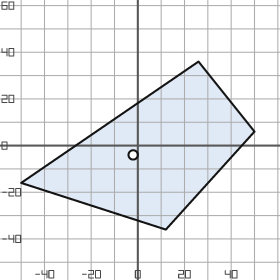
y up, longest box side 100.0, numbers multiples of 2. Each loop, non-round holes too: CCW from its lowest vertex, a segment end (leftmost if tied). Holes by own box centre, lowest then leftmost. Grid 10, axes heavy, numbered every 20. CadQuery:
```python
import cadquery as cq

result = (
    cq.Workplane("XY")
    .moveTo(12.0, -36.0)
    .lineTo(50.0, 6.0)
    .lineTo(26.0, 36.0)
    .lineTo(-50.0, -16.0)
    .close()
    .moveTo(-2.0, -4.0)
    .circle(2.0)
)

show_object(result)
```